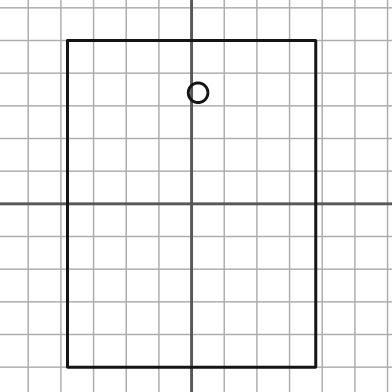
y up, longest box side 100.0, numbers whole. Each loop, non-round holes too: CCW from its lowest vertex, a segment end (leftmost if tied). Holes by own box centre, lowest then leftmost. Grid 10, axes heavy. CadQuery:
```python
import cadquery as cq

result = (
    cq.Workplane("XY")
    .moveTo(-38.0, -50.0)
    .lineTo(38.0, -50.0)
    .lineTo(38.0, 50.0)
    .lineTo(-38.0, 50.0)
    .close()
    .moveTo(2.0, 34.0)
    .circle(3.0)
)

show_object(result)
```